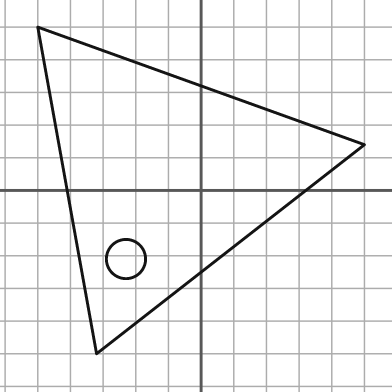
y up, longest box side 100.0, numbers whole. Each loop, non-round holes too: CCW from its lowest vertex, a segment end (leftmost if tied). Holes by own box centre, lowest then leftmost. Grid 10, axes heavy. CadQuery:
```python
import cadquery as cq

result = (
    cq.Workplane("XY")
    .moveTo(-32.0, -50.0)
    .lineTo(50.0, 14.0)
    .lineTo(-50.0, 50.0)
    .close()
    .moveTo(-23.0, -21.0)
    .circle(6.0)
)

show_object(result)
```